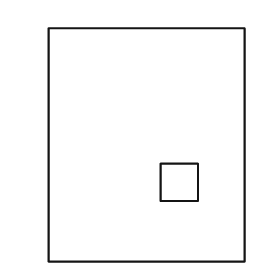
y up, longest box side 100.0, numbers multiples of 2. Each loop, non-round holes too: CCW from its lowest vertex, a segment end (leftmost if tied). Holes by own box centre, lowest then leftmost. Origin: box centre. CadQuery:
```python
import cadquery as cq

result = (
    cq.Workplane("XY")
    .moveTo(-42.0, -50.0)
    .lineTo(42.0, -50.0)
    .lineTo(42.0, 50.0)
    .lineTo(-42.0, 50.0)
    .close()
    .moveTo(6.0, -24.0)
    .lineTo(22.0, -24.0)
    .lineTo(22.0, -8.0)
    .lineTo(6.0, -8.0)
    .close()
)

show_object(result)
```